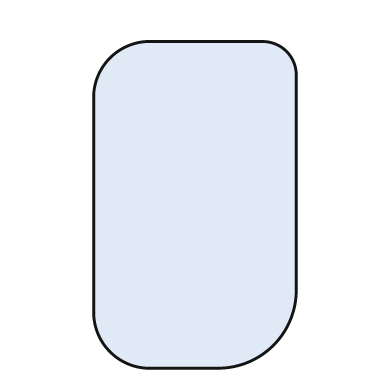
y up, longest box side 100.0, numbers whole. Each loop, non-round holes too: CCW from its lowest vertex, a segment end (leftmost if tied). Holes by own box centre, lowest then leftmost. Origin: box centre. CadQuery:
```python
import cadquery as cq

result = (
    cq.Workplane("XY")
    .moveTo(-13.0, -50.0)
    .lineTo(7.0, -50.0)
    .threePointArc((24.0, -43.0), (31.0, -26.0))
    .lineTo(31.0, 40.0)
    .threePointArc((28.0, 47.0), (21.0, 50.0))
    .lineTo(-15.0, 50.0)
    .threePointArc((-26.0, 45.0), (-31.0, 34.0))
    .lineTo(-31.0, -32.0)
    .threePointArc((-26.0, -45.0), (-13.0, -50.0))
    .close()
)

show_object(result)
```